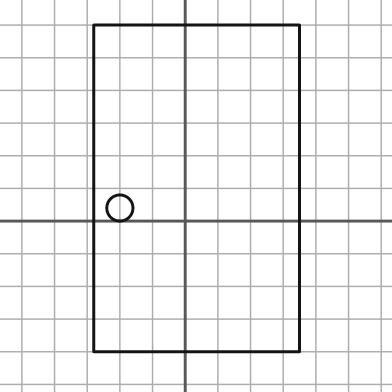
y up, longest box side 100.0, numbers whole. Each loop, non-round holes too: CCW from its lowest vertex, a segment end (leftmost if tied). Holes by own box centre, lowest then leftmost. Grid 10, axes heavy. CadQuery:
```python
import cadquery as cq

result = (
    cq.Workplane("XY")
    .moveTo(-28.0, -40.0)
    .lineTo(35.0, -40.0)
    .lineTo(35.0, 60.0)
    .lineTo(-28.0, 60.0)
    .close()
    .moveTo(-20.0, 4.0)
    .circle(4.0)
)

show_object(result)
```